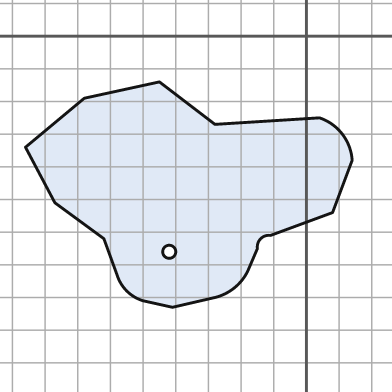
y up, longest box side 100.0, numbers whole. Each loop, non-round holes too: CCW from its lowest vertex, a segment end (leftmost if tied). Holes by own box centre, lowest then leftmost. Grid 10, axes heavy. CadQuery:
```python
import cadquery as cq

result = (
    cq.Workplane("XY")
    .moveTo(-41.0, -83.0)
    .lineTo(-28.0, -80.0)
    .threePointArc((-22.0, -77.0), (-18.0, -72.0))
    .lineTo(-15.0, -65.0)
    .threePointArc((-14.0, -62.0), (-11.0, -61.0))
    .lineTo(8.0, -54.0)
    .lineTo(14.0, -38.0)
    .threePointArc((11.0, -30.0), (4.0, -25.0))
    .lineTo(-28.0, -27.0)
    .lineTo(-45.0, -14.0)
    .lineTo(-68.0, -19.0)
    .lineTo(-86.0, -34.0)
    .lineTo(-77.0, -51.0)
    .lineTo(-62.0, -62.0)
    .lineTo(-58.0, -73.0)
    .threePointArc((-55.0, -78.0), (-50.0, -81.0))
    .close()
    .moveTo(-42.0, -66.0)
    .circle(2.0)
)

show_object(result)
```